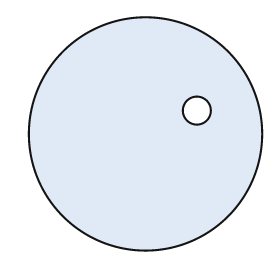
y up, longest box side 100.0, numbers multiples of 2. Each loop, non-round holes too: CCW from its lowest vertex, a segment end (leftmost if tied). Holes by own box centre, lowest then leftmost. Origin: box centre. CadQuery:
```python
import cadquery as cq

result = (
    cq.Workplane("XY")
    .moveTo(0.0, 0.0)
    .circle(50.0)
    .moveTo(22.0, 10.0)
    .circle(6.0)
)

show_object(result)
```